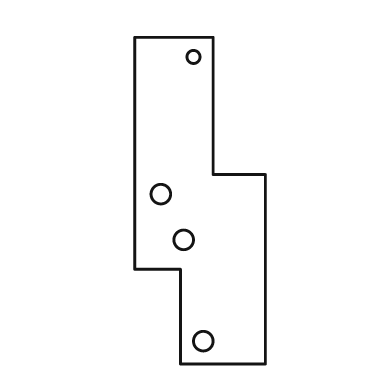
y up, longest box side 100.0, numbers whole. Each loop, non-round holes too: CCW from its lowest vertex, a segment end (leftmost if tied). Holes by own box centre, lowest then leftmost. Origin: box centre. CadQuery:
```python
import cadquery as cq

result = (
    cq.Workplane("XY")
    .moveTo(-6.0, -50.0)
    .lineTo(20.0, -50.0)
    .lineTo(20.0, 8.0)
    .lineTo(4.0, 8.0)
    .lineTo(4.0, 50.0)
    .lineTo(-20.0, 50.0)
    .lineTo(-20.0, -21.0)
    .lineTo(-6.0, -21.0)
    .close()
    .moveTo(1.0, -43.0)
    .circle(3.0)
    .moveTo(-5.0, -12.0)
    .circle(3.0)
    .moveTo(-12.0, 2.0)
    .circle(3.0)
    .moveTo(-2.0, 44.0)
    .circle(2.0)
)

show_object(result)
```